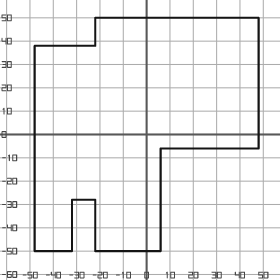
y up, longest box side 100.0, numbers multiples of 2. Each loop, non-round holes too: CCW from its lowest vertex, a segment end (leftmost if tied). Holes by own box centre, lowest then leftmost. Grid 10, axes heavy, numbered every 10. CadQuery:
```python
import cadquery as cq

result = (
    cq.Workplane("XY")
    .moveTo(-48.0, -50.0)
    .lineTo(-32.0, -50.0)
    .lineTo(-32.0, -28.0)
    .lineTo(-22.0, -28.0)
    .lineTo(-22.0, -50.0)
    .lineTo(6.0, -50.0)
    .lineTo(6.0, -6.0)
    .lineTo(48.0, -6.0)
    .lineTo(48.0, 50.0)
    .lineTo(-22.0, 50.0)
    .lineTo(-22.0, 38.0)
    .lineTo(-48.0, 38.0)
    .close()
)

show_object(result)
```